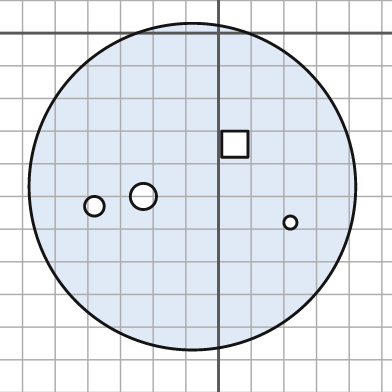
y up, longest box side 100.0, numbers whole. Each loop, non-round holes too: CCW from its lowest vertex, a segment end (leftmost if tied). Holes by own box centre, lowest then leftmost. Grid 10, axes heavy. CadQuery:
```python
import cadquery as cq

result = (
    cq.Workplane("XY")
    .moveTo(-8.0, -47.0)
    .circle(50.0)
    .moveTo(22.0, -58.0)
    .circle(2.0)
    .moveTo(-38.0, -53.0)
    .circle(3.0)
    .moveTo(-23.0, -50.0)
    .circle(4.0)
    .moveTo(1.0, -38.0)
    .lineTo(9.0, -38.0)
    .lineTo(9.0, -30.0)
    .lineTo(1.0, -30.0)
    .close()
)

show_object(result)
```